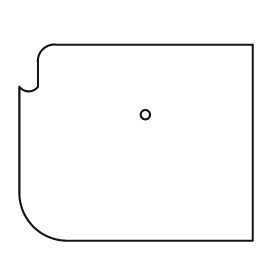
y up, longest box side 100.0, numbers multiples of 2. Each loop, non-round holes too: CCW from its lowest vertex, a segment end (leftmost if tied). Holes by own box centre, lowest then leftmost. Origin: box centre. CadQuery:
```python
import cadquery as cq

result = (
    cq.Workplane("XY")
    .moveTo(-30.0, -42.0)
    .lineTo(50.0, -42.0)
    .lineTo(50.0, 42.0)
    .lineTo(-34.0, 42.0)
    .threePointArc((-40.0, 40.0), (-42.0, 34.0))
    .lineTo(-42.0, 24.0)
    .threePointArc((-46.0, 22.0), (-50.0, 24.0))
    .lineTo(-50.0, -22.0)
    .threePointArc((-44.0, -36.0), (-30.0, -42.0))
    .close()
    .moveTo(4.0, 12.0)
    .circle(2.0)
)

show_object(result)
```